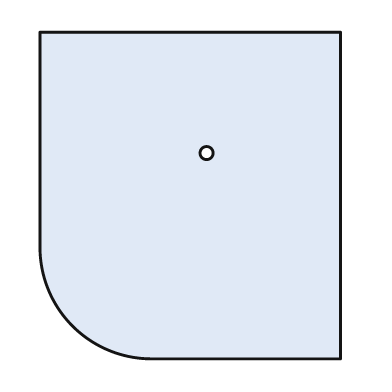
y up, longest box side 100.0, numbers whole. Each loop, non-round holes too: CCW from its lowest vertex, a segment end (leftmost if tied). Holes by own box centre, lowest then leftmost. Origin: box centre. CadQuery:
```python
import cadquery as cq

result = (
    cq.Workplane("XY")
    .moveTo(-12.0, -50.0)
    .lineTo(46.0, -50.0)
    .lineTo(46.0, 50.0)
    .lineTo(-46.0, 50.0)
    .lineTo(-46.0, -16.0)
    .threePointArc((-36.0, -40.0), (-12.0, -50.0))
    .close()
    .moveTo(5.0, 13.0)
    .circle(2.0)
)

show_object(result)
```